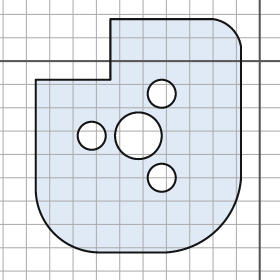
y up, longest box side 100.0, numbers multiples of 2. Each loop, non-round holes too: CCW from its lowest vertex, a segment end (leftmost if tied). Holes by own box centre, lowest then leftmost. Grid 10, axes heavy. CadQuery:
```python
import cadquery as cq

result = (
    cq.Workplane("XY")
    .moveTo(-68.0, -82.0)
    .lineTo(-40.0, -82.0)
    .threePointArc((-18.0, -72.0), (-8.0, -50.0))
    .lineTo(-8.0, 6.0)
    .threePointArc((-12.0, 14.0), (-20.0, 18.0))
    .lineTo(-64.0, 18.0)
    .lineTo(-64.0, -8.0)
    .lineTo(-96.0, -8.0)
    .lineTo(-96.0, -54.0)
    .threePointArc((-88.0, -74.0), (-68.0, -82.0))
    .close()
    .moveTo(-42.0, -50.0)
    .circle(6.0)
    .moveTo(-72.0, -32.0)
    .circle(6.0)
    .moveTo(-52.0, -32.0)
    .circle(10.0)
    .moveTo(-42.0, -14.0)
    .circle(6.0)
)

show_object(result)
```